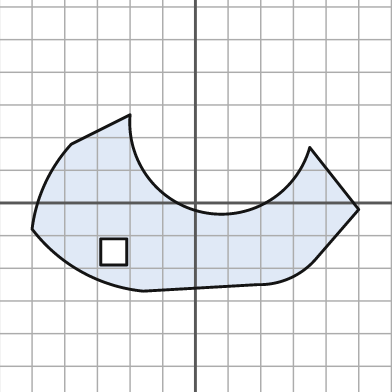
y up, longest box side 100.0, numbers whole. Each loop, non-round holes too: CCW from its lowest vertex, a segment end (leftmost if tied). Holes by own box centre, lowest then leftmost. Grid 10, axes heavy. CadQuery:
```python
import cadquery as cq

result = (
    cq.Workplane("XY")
    .moveTo(-16.0, -27.0)
    .lineTo(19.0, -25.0)
    .threePointArc((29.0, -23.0), (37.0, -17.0))
    .lineTo(50.0, -2.0)
    .lineTo(35.0, 17.0)
    .threePointArc((3.0, -3.0), (-20.0, 27.0))
    .lineTo(-38.0, 18.0)
    .threePointArc((-46.0, 6.0), (-50.0, -8.0))
    .threePointArc((-35.0, -21.0), (-16.0, -27.0))
    .close()
    .moveTo(-29.0, -19.0)
    .lineTo(-21.0, -19.0)
    .lineTo(-21.0, -11.0)
    .lineTo(-29.0, -11.0)
    .close()
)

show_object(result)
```